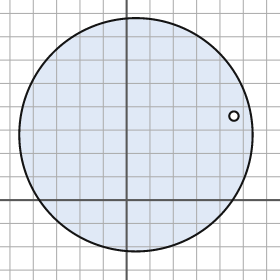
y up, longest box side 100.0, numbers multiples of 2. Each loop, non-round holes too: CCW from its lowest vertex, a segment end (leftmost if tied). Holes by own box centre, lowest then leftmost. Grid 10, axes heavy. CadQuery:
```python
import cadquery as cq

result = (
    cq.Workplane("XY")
    .moveTo(4.0, 28.0)
    .circle(50.0)
    .moveTo(46.0, 36.0)
    .circle(2.0)
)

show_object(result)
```